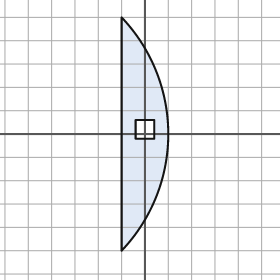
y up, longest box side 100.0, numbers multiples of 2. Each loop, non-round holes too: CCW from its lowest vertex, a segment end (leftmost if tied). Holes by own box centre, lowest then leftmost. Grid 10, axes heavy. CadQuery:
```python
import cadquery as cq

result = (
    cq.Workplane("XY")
    .moveTo(-10.0, -50.0)
    .threePointArc((10.0, 0.0), (-10.0, 50.0))
    .close()
    .moveTo(-4.0, -2.0)
    .lineTo(4.0, -2.0)
    .lineTo(4.0, 6.0)
    .lineTo(-4.0, 6.0)
    .close()
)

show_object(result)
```